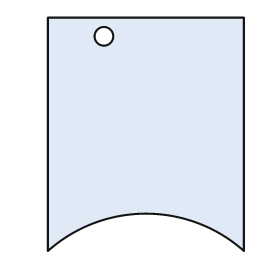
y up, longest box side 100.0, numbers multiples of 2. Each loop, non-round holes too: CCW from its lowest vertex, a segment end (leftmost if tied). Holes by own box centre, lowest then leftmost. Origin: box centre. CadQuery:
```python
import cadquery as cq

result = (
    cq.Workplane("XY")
    .moveTo(-42.0, -50.0)
    .threePointArc((0.0, -34.0), (42.0, -50.0))
    .lineTo(42.0, 50.0)
    .lineTo(-42.0, 50.0)
    .close()
    .moveTo(-18.0, 42.0)
    .circle(4.0)
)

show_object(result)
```